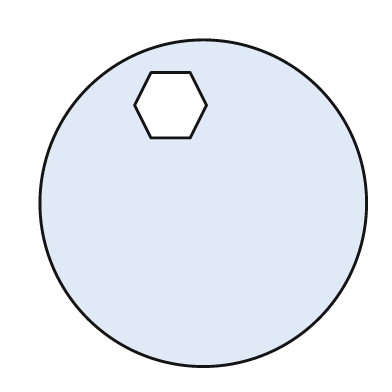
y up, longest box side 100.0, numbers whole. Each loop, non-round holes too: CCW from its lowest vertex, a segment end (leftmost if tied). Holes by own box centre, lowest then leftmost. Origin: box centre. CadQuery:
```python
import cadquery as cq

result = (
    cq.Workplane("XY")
    .moveTo(0.0, 0.0)
    .circle(50.0)
    .moveTo(-16.0, 20.0)
    .lineTo(-4.0, 20.0)
    .lineTo(1.0, 30.0)
    .lineTo(-4.0, 40.0)
    .lineTo(-16.0, 40.0)
    .lineTo(-21.0, 30.0)
    .close()
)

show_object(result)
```